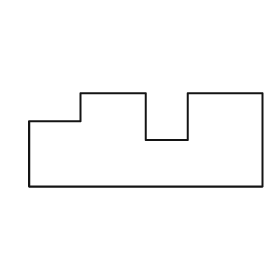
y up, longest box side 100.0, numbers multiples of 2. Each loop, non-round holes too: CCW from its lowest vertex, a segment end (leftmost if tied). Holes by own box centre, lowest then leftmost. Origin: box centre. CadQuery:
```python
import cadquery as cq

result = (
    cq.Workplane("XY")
    .moveTo(-50.0, -20.0)
    .lineTo(50.0, -20.0)
    .lineTo(50.0, 20.0)
    .lineTo(18.0, 20.0)
    .lineTo(18.0, 0.0)
    .lineTo(0.0, 0.0)
    .lineTo(0.0, 20.0)
    .lineTo(-28.0, 20.0)
    .lineTo(-28.0, 8.0)
    .lineTo(-50.0, 8.0)
    .close()
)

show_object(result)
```